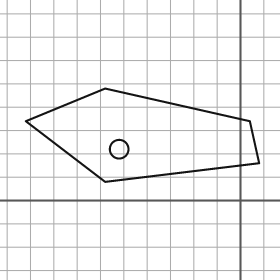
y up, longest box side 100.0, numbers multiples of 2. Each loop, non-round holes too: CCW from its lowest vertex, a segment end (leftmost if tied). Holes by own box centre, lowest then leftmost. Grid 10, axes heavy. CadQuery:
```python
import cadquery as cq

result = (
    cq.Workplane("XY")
    .moveTo(-58.0, 8.0)
    .lineTo(8.0, 16.0)
    .lineTo(4.0, 34.0)
    .lineTo(-58.0, 48.0)
    .lineTo(-92.0, 34.0)
    .close()
    .moveTo(-52.0, 22.0)
    .circle(4.0)
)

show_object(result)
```